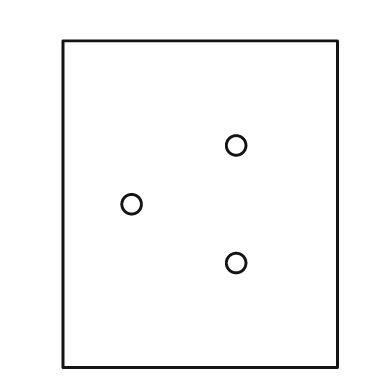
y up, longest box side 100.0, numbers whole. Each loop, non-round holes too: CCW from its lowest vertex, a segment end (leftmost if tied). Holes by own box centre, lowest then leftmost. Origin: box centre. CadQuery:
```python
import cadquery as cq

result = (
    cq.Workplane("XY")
    .moveTo(-42.0, -50.0)
    .lineTo(42.0, -50.0)
    .lineTo(42.0, 50.0)
    .lineTo(-42.0, 50.0)
    .close()
    .moveTo(11.0, -18.0)
    .circle(3.0)
    .moveTo(-21.0, 0.0)
    .circle(3.0)
    .moveTo(11.0, 18.0)
    .circle(3.0)
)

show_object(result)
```